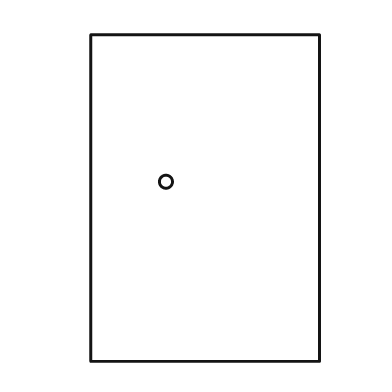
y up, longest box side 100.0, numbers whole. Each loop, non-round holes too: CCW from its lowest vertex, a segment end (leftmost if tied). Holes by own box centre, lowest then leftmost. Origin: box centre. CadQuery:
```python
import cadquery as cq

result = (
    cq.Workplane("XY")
    .moveTo(-35.0, -50.0)
    .lineTo(35.0, -50.0)
    .lineTo(35.0, 50.0)
    .lineTo(-35.0, 50.0)
    .close()
    .moveTo(-12.0, 5.0)
    .circle(2.0)
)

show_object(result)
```